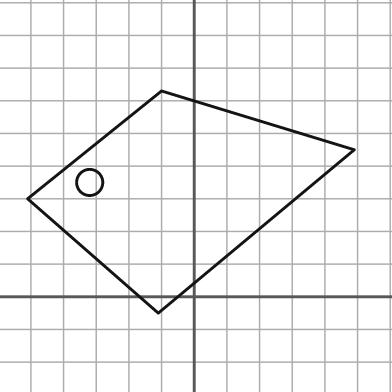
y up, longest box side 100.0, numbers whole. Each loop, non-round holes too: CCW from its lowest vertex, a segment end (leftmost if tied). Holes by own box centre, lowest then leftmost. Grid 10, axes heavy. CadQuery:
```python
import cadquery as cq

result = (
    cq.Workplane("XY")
    .moveTo(-11.0, -5.0)
    .lineTo(49.0, 45.0)
    .lineTo(-10.0, 63.0)
    .lineTo(-51.0, 30.0)
    .close()
    .moveTo(-32.0, 35.0)
    .circle(4.0)
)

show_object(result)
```